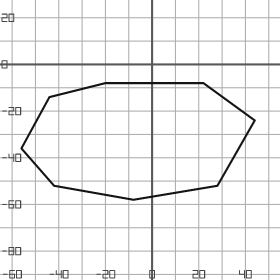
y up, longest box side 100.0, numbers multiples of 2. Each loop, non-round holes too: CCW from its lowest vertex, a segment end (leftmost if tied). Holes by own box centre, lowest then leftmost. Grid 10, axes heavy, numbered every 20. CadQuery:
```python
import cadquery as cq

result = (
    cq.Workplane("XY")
    .moveTo(-8.0, -58.0)
    .lineTo(28.0, -52.0)
    .lineTo(44.0, -24.0)
    .lineTo(22.0, -8.0)
    .lineTo(-20.0, -8.0)
    .lineTo(-44.0, -14.0)
    .lineTo(-56.0, -36.0)
    .lineTo(-42.0, -52.0)
    .close()
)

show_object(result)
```